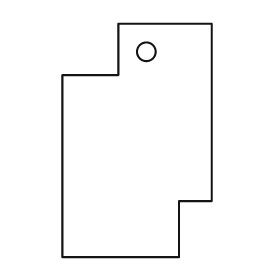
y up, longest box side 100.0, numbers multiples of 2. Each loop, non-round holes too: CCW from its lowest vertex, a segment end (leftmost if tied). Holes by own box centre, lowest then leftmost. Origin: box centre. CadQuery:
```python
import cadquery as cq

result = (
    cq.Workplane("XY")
    .moveTo(-32.0, -50.0)
    .lineTo(18.0, -50.0)
    .lineTo(18.0, -26.0)
    .lineTo(32.0, -26.0)
    .lineTo(32.0, 50.0)
    .lineTo(-8.0, 50.0)
    .lineTo(-8.0, 28.0)
    .lineTo(-32.0, 28.0)
    .close()
    .moveTo(4.0, 38.0)
    .circle(4.0)
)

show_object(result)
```